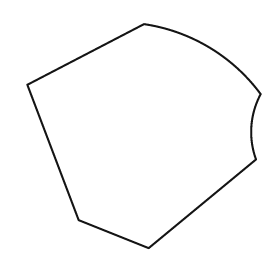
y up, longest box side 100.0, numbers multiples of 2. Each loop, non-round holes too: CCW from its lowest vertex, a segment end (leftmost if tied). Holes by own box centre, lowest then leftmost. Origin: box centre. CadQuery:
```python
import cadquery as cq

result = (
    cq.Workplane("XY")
    .moveTo(2.0, -48.0)
    .lineTo(48.0, -10.0)
    .threePointArc((46.0, 4.0), (50.0, 18.0))
    .threePointArc((28.0, 38.0), (0.0, 48.0))
    .lineTo(-50.0, 22.0)
    .lineTo(-28.0, -36.0)
    .close()
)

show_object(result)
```